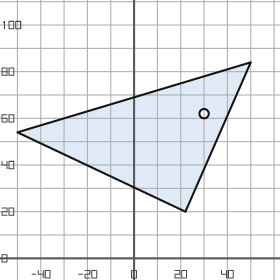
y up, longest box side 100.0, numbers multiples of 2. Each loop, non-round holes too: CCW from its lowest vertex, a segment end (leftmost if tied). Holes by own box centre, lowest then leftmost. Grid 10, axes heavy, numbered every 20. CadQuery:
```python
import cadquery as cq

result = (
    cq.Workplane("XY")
    .moveTo(22.0, 20.0)
    .lineTo(50.0, 84.0)
    .lineTo(-50.0, 54.0)
    .close()
    .moveTo(30.0, 62.0)
    .circle(2.0)
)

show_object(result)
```